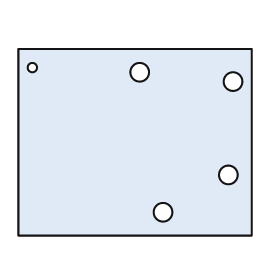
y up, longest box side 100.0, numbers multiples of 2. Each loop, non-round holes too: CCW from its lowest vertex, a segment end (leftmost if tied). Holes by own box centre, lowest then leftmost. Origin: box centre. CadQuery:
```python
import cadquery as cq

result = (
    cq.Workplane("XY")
    .moveTo(-50.0, -40.0)
    .lineTo(50.0, -40.0)
    .lineTo(50.0, 40.0)
    .lineTo(-50.0, 40.0)
    .close()
    .moveTo(12.0, -30.0)
    .circle(4.0)
    .moveTo(40.0, -14.0)
    .circle(4.0)
    .moveTo(42.0, 26.0)
    .circle(4.0)
    .moveTo(2.0, 30.0)
    .circle(4.0)
    .moveTo(-44.0, 32.0)
    .circle(2.0)
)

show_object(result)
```